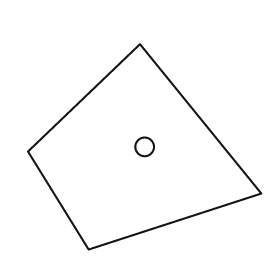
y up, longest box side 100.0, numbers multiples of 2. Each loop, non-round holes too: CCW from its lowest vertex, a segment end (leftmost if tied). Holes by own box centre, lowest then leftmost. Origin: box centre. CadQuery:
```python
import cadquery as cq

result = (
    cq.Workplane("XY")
    .moveTo(-24.0, -44.0)
    .lineTo(50.0, -20.0)
    .lineTo(-2.0, 44.0)
    .lineTo(-50.0, -2.0)
    .close()
    .moveTo(0.0, 0.0)
    .circle(4.0)
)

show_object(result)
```